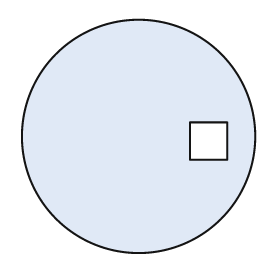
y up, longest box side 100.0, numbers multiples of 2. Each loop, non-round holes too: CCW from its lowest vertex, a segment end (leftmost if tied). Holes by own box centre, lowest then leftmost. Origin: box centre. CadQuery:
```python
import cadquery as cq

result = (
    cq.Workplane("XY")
    .moveTo(0.0, 0.0)
    .circle(50.0)
    .moveTo(22.0, -10.0)
    .lineTo(38.0, -10.0)
    .lineTo(38.0, 6.0)
    .lineTo(22.0, 6.0)
    .close()
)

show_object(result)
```